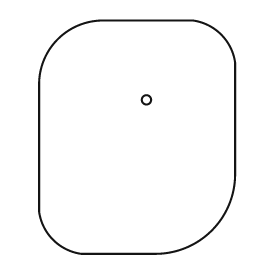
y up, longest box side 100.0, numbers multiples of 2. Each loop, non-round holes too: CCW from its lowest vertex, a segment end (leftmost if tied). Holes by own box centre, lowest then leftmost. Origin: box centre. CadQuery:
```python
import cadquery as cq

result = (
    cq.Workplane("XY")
    .moveTo(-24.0, -50.0)
    .lineTo(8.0, -50.0)
    .threePointArc((32.0, -40.0), (42.0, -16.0))
    .lineTo(42.0, 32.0)
    .threePointArc((36.0, 44.0), (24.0, 50.0))
    .lineTo(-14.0, 50.0)
    .threePointArc((-34.0, 42.0), (-42.0, 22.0))
    .lineTo(-42.0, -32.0)
    .threePointArc((-36.0, -44.0), (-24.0, -50.0))
    .close()
    .moveTo(4.0, 16.0)
    .circle(2.0)
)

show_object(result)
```